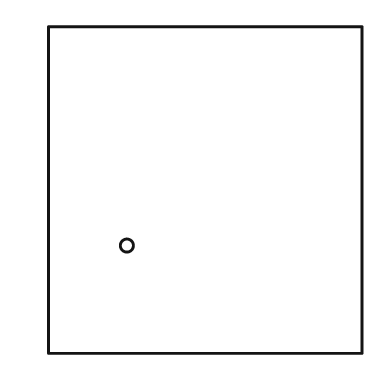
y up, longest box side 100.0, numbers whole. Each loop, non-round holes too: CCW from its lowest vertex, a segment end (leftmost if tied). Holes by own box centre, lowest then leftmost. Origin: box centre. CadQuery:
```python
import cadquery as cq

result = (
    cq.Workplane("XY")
    .moveTo(-48.0, -50.0)
    .lineTo(48.0, -50.0)
    .lineTo(48.0, 50.0)
    .lineTo(-48.0, 50.0)
    .close()
    .moveTo(-24.0, -17.0)
    .circle(2.0)
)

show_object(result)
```